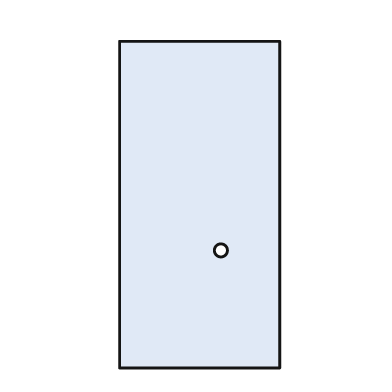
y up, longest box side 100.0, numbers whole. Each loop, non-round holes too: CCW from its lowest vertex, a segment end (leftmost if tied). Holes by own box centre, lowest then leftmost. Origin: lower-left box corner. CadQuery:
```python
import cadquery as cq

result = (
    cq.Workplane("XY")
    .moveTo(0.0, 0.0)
    .lineTo(49.0, 0.0)
    .lineTo(49.0, 100.0)
    .lineTo(0.0, 100.0)
    .close()
    .moveTo(31.0, 36.0)
    .circle(2.0)
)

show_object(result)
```